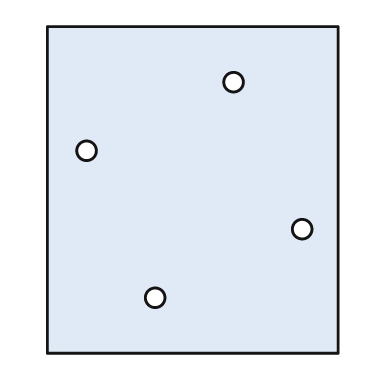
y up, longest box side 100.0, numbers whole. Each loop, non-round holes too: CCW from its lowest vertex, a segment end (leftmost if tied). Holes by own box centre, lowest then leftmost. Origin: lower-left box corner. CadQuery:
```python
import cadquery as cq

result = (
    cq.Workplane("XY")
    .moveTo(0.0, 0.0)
    .lineTo(89.0, 0.0)
    .lineTo(89.0, 100.0)
    .lineTo(0.0, 100.0)
    .close()
    .moveTo(33.0, 17.0)
    .circle(3.0)
    .moveTo(78.0, 38.0)
    .circle(3.0)
    .moveTo(12.0, 62.0)
    .circle(3.0)
    .moveTo(57.0, 83.0)
    .circle(3.0)
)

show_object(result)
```